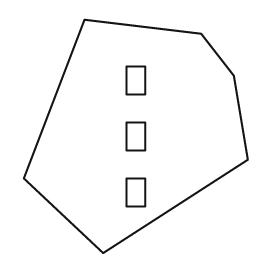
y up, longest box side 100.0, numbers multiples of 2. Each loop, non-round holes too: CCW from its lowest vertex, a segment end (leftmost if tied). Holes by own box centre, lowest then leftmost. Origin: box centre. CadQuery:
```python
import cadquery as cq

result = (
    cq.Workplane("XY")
    .moveTo(-14.0, -50.0)
    .lineTo(48.0, -10.0)
    .lineTo(42.0, 26.0)
    .lineTo(28.0, 44.0)
    .lineTo(-22.0, 50.0)
    .lineTo(-48.0, -18.0)
    .close()
    .moveTo(-4.0, -30.0)
    .lineTo(4.0, -30.0)
    .lineTo(4.0, -18.0)
    .lineTo(-4.0, -18.0)
    .close()
    .moveTo(-4.0, -6.0)
    .lineTo(4.0, -6.0)
    .lineTo(4.0, 6.0)
    .lineTo(-4.0, 6.0)
    .close()
    .moveTo(-4.0, 18.0)
    .lineTo(4.0, 18.0)
    .lineTo(4.0, 30.0)
    .lineTo(-4.0, 30.0)
    .close()
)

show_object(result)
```